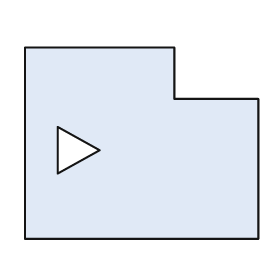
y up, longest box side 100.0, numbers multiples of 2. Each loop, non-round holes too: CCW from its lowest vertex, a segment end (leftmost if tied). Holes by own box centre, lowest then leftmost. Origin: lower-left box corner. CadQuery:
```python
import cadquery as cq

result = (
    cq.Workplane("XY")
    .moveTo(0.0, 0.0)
    .lineTo(100.0, 0.0)
    .lineTo(100.0, 60.0)
    .lineTo(64.0, 60.0)
    .lineTo(64.0, 82.0)
    .lineTo(0.0, 82.0)
    .close()
    .moveTo(14.0, 28.0)
    .lineTo(32.0, 38.0)
    .lineTo(14.0, 48.0)
    .close()
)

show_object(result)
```